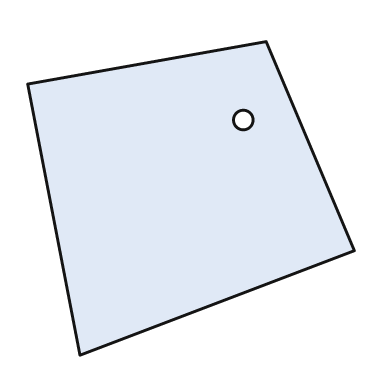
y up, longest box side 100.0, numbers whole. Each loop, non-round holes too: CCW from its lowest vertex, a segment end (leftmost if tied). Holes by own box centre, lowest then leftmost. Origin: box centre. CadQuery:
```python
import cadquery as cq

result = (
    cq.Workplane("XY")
    .moveTo(-34.0, -48.0)
    .lineTo(50.0, -16.0)
    .lineTo(23.0, 48.0)
    .lineTo(-50.0, 35.0)
    .close()
    .moveTo(16.0, 24.0)
    .circle(3.0)
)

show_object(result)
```